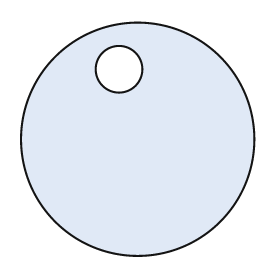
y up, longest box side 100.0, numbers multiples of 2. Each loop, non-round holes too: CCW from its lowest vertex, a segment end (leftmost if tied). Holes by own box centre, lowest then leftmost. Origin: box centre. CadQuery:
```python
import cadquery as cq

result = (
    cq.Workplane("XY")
    .moveTo(0.0, 0.0)
    .circle(50.0)
    .moveTo(-8.0, 30.0)
    .circle(10.0)
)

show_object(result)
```